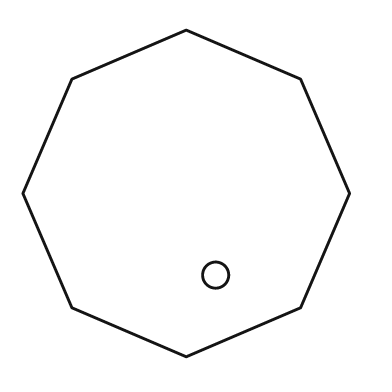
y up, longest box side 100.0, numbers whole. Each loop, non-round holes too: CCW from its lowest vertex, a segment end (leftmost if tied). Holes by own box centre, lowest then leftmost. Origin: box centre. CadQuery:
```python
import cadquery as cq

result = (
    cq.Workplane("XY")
    .moveTo(0.0, -50.0)
    .lineTo(35.0, -35.0)
    .lineTo(50.0, 0.0)
    .lineTo(35.0, 35.0)
    .lineTo(0.0, 50.0)
    .lineTo(-35.0, 35.0)
    .lineTo(-50.0, 0.0)
    .lineTo(-35.0, -35.0)
    .close()
    .moveTo(9.0, -25.0)
    .circle(4.0)
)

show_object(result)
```